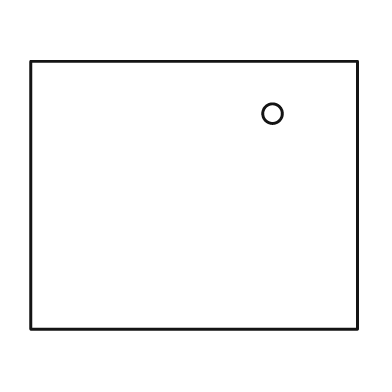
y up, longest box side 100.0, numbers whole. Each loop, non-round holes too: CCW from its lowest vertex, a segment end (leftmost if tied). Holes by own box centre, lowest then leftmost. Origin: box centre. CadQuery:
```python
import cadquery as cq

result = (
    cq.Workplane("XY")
    .moveTo(-50.0, -41.0)
    .lineTo(50.0, -41.0)
    .lineTo(50.0, 41.0)
    .lineTo(-50.0, 41.0)
    .close()
    .moveTo(24.0, 25.0)
    .circle(3.0)
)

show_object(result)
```